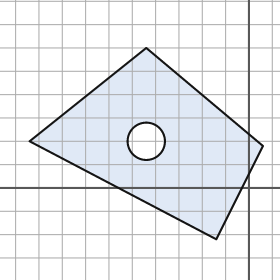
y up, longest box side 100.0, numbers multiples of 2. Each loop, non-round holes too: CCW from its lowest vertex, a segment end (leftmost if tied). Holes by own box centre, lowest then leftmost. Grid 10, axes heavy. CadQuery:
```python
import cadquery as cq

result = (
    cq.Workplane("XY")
    .moveTo(-14.0, -22.0)
    .lineTo(6.0, 18.0)
    .lineTo(-44.0, 60.0)
    .lineTo(-94.0, 20.0)
    .close()
    .moveTo(-44.0, 20.0)
    .circle(8.0)
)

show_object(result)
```